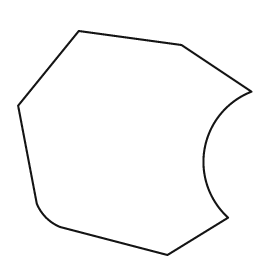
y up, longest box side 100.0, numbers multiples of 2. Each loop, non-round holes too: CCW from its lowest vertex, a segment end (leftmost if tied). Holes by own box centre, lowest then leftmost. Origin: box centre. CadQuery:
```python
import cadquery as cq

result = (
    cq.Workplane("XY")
    .moveTo(14.0, -48.0)
    .lineTo(40.0, -32.0)
    .threePointArc((30.0, -2.0), (50.0, 22.0))
    .lineTo(20.0, 42.0)
    .lineTo(-24.0, 48.0)
    .lineTo(-50.0, 16.0)
    .lineTo(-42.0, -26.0)
    .threePointArc((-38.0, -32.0), (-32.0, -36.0))
    .close()
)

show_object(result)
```